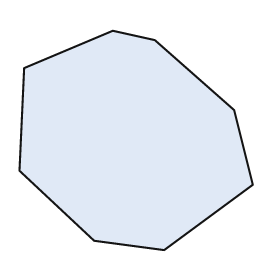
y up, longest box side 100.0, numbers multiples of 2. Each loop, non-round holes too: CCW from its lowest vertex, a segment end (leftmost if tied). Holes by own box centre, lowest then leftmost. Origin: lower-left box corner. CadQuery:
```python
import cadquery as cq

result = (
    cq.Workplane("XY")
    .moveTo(62.0, 0.0)
    .lineTo(100.0, 28.0)
    .lineTo(92.0, 60.0)
    .lineTo(58.0, 90.0)
    .lineTo(40.0, 94.0)
    .lineTo(2.0, 78.0)
    .lineTo(0.0, 34.0)
    .lineTo(32.0, 4.0)
    .close()
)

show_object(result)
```